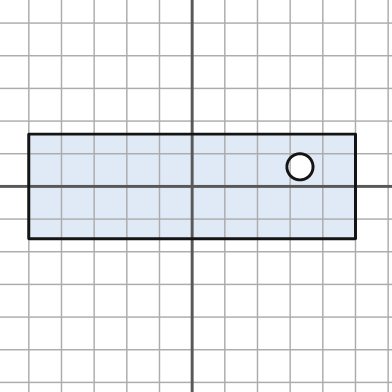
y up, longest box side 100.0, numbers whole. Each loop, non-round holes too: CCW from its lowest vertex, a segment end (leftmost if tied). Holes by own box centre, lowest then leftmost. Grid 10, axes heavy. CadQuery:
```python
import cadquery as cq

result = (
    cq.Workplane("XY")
    .moveTo(-50.0, -16.0)
    .lineTo(50.0, -16.0)
    .lineTo(50.0, 16.0)
    .lineTo(-50.0, 16.0)
    .close()
    .moveTo(33.0, 6.0)
    .circle(4.0)
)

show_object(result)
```